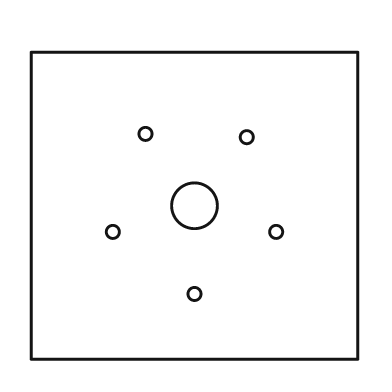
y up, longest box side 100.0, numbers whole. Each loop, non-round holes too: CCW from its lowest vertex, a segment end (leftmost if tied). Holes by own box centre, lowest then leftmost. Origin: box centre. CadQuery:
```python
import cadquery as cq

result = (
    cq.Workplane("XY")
    .moveTo(-50.0, -47.0)
    .lineTo(50.0, -47.0)
    .lineTo(50.0, 47.0)
    .lineTo(-50.0, 47.0)
    .close()
    .moveTo(0.0, -27.0)
    .circle(2.0)
    .moveTo(-25.0, -8.0)
    .circle(2.0)
    .moveTo(25.0, -8.0)
    .circle(2.0)
    .moveTo(0.0, 0.0)
    .circle(7.0)
    .moveTo(16.0, 21.0)
    .circle(2.0)
    .moveTo(-15.0, 22.0)
    .circle(2.0)
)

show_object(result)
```